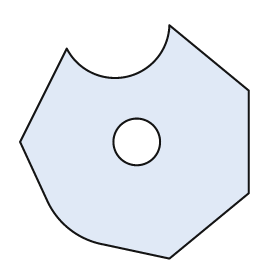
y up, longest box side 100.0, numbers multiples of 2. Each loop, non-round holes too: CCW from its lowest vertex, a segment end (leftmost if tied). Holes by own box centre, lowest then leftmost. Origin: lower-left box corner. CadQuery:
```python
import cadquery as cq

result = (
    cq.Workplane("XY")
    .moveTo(64.0, 0.0)
    .lineTo(98.0, 28.0)
    .lineTo(98.0, 72.0)
    .lineTo(64.0, 100.0)
    .threePointArc((46.0, 78.0), (20.0, 90.0))
    .lineTo(0.0, 50.0)
    .lineTo(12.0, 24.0)
    .threePointArc((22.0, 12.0), (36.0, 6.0))
    .close()
    .moveTo(50.0, 50.0)
    .circle(10.0)
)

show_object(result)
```